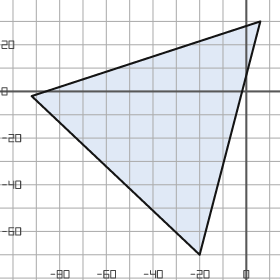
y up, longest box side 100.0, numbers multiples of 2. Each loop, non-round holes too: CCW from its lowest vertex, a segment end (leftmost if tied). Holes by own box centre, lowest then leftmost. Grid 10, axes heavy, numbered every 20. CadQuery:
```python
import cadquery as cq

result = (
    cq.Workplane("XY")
    .moveTo(-20.0, -70.0)
    .lineTo(6.0, 30.0)
    .lineTo(-92.0, -2.0)
    .close()
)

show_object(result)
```